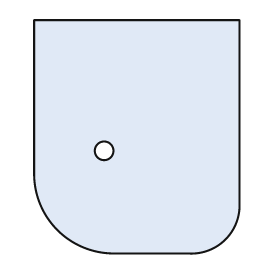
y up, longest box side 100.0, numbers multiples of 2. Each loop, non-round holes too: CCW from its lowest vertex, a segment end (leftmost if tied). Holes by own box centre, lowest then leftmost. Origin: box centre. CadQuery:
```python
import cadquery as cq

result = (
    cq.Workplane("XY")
    .moveTo(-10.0, -50.0)
    .lineTo(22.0, -50.0)
    .threePointArc((38.0, -44.0), (44.0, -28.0))
    .lineTo(44.0, 50.0)
    .lineTo(-44.0, 50.0)
    .lineTo(-44.0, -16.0)
    .threePointArc((-34.0, -40.0), (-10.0, -50.0))
    .close()
    .moveTo(-14.0, -6.0)
    .circle(4.0)
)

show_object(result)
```